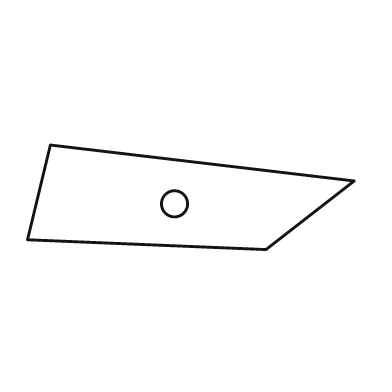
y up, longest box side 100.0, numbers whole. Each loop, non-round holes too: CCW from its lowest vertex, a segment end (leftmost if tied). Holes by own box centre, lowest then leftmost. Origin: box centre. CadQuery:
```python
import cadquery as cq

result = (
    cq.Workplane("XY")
    .moveTo(23.0, -16.0)
    .lineTo(50.0, 5.0)
    .lineTo(-43.0, 16.0)
    .lineTo(-50.0, -13.0)
    .close()
    .moveTo(-5.0, -2.0)
    .circle(4.0)
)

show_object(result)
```